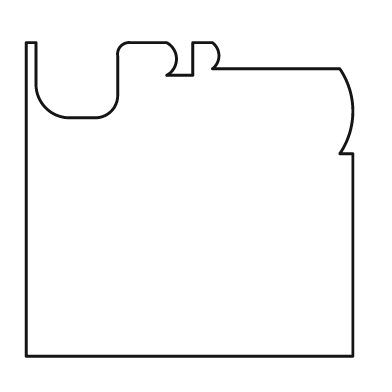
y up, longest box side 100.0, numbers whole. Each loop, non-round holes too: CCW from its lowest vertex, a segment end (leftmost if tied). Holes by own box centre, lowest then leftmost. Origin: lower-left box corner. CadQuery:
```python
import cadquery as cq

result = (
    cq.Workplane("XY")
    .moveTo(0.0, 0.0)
    .lineTo(100.0, 0.0)
    .lineTo(100.0, 62.0)
    .lineTo(96.0, 62.0)
    .threePointArc((100.0, 75.0), (96.0, 88.0))
    .lineTo(57.0, 88.0)
    .threePointArc((59.0, 92.0), (57.0, 96.0))
    .lineTo(51.0, 96.0)
    .lineTo(51.0, 86.0)
    .lineTo(43.0, 86.0)
    .threePointArc((46.0, 91.0), (43.0, 96.0))
    .lineTo(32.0, 96.0)
    .threePointArc((29.0, 95.0), (28.0, 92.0))
    .lineTo(28.0, 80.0)
    .threePointArc((26.0, 75.0), (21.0, 73.0))
    .lineTo(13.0, 73.0)
    .threePointArc((6.0, 76.0), (3.0, 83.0))
    .lineTo(3.0, 96.0)
    .lineTo(0.0, 96.0)
    .close()
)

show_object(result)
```